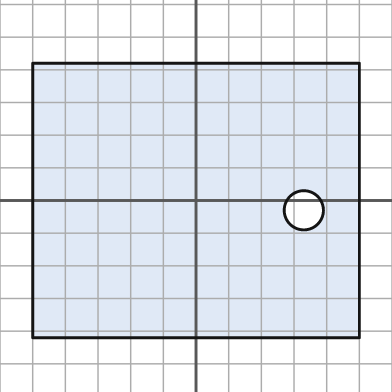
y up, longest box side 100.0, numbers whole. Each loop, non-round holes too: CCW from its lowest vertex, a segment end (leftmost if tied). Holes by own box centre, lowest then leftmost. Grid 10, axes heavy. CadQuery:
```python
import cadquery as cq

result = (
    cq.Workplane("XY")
    .moveTo(-50.0, -42.0)
    .lineTo(50.0, -42.0)
    .lineTo(50.0, 42.0)
    .lineTo(-50.0, 42.0)
    .close()
    .moveTo(33.0, -3.0)
    .circle(6.0)
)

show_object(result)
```